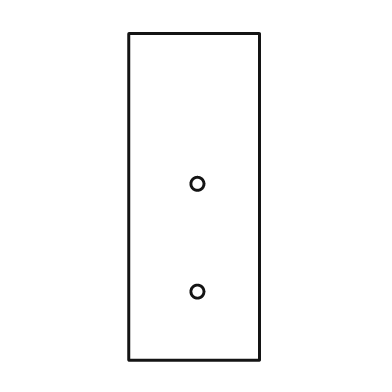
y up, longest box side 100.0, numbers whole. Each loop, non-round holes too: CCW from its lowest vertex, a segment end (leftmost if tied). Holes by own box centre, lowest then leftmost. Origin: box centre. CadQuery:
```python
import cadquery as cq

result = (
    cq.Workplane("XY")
    .moveTo(-20.0, -50.0)
    .lineTo(20.0, -50.0)
    .lineTo(20.0, 50.0)
    .lineTo(-20.0, 50.0)
    .close()
    .moveTo(1.0, -29.0)
    .circle(2.0)
    .moveTo(1.0, 4.0)
    .circle(2.0)
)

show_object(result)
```